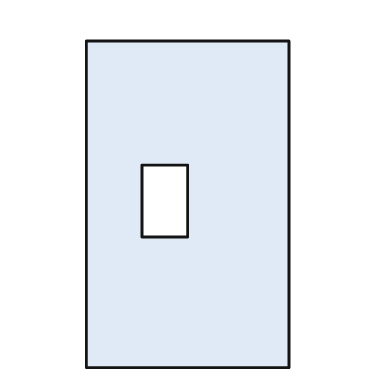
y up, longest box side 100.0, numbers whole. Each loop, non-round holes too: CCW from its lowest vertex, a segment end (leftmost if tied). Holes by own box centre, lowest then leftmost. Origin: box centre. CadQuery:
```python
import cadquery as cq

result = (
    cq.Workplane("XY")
    .moveTo(-31.0, -50.0)
    .lineTo(31.0, -50.0)
    .lineTo(31.0, 50.0)
    .lineTo(-31.0, 50.0)
    .close()
    .moveTo(-14.0, -10.0)
    .lineTo(0.0, -10.0)
    .lineTo(0.0, 12.0)
    .lineTo(-14.0, 12.0)
    .close()
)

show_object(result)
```